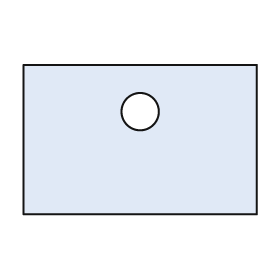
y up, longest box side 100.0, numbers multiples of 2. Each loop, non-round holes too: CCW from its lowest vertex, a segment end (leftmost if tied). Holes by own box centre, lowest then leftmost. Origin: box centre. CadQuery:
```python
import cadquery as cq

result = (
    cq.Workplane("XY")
    .moveTo(-50.0, -32.0)
    .lineTo(50.0, -32.0)
    .lineTo(50.0, 32.0)
    .lineTo(-50.0, 32.0)
    .close()
    .moveTo(0.0, 12.0)
    .circle(8.0)
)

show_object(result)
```